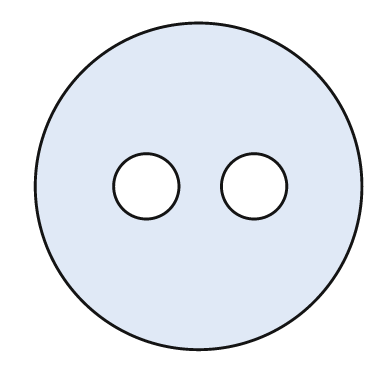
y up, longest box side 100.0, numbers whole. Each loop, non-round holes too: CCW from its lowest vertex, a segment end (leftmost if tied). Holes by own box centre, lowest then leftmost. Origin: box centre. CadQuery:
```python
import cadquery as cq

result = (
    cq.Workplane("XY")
    .moveTo(0.0, 0.0)
    .circle(50.0)
    .moveTo(-16.0, 0.0)
    .circle(10.0)
    .moveTo(17.0, 0.0)
    .circle(10.0)
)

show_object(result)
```